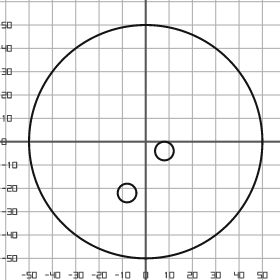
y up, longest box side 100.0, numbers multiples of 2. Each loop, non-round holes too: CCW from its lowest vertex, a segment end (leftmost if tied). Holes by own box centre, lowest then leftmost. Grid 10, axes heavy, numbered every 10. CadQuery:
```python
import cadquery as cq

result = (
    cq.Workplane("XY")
    .moveTo(0.0, 0.0)
    .circle(50.0)
    .moveTo(-8.0, -22.0)
    .circle(4.0)
    .moveTo(8.0, -4.0)
    .circle(4.0)
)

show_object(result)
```